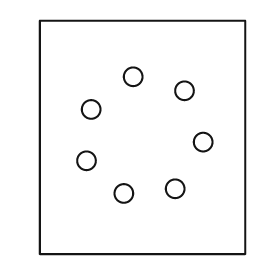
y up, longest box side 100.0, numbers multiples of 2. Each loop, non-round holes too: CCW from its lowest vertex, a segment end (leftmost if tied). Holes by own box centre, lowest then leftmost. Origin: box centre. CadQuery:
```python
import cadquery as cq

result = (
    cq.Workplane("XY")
    .moveTo(-44.0, -50.0)
    .lineTo(44.0, -50.0)
    .lineTo(44.0, 50.0)
    .lineTo(-44.0, 50.0)
    .close()
    .moveTo(-8.0, -24.0)
    .circle(4.0)
    .moveTo(14.0, -22.0)
    .circle(4.0)
    .moveTo(-24.0, -10.0)
    .circle(4.0)
    .moveTo(26.0, -2.0)
    .circle(4.0)
    .moveTo(-22.0, 12.0)
    .circle(4.0)
    .moveTo(18.0, 20.0)
    .circle(4.0)
    .moveTo(-4.0, 26.0)
    .circle(4.0)
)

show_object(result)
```